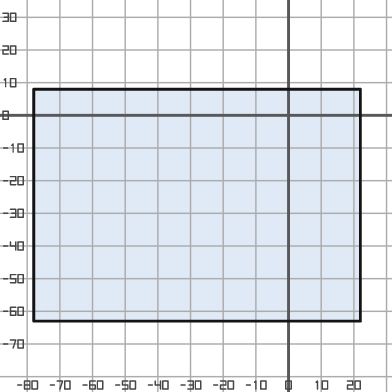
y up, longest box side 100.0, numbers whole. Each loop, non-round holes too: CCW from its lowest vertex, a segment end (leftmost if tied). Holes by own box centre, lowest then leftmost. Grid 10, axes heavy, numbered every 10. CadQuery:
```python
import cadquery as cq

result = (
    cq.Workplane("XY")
    .moveTo(-78.0, -63.0)
    .lineTo(22.0, -63.0)
    .lineTo(22.0, 8.0)
    .lineTo(-78.0, 8.0)
    .close()
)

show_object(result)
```